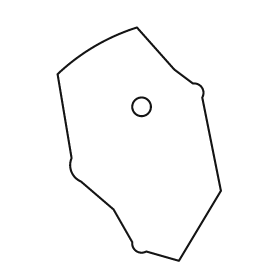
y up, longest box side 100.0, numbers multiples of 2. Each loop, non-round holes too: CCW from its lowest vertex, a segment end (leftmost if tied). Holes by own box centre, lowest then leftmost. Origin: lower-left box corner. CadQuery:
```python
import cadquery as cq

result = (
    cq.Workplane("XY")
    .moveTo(52.0, 0.0)
    .lineTo(70.0, 30.0)
    .lineTo(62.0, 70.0)
    .threePointArc((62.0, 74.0), (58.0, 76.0))
    .lineTo(50.0, 82.0)
    .lineTo(34.0, 100.0)
    .threePointArc((16.0, 92.0), (0.0, 80.0))
    .lineTo(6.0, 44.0)
    .threePointArc((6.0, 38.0), (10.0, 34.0))
    .lineTo(24.0, 22.0)
    .lineTo(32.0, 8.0)
    .threePointArc((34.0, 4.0), (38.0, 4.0))
    .close()
    .moveTo(36.0, 66.0)
    .circle(4.0)
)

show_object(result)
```